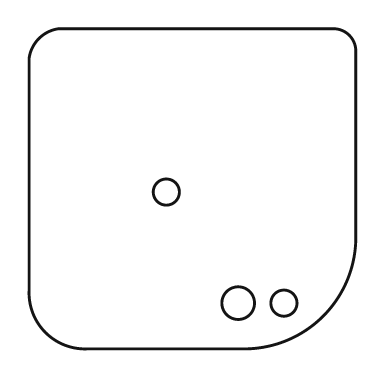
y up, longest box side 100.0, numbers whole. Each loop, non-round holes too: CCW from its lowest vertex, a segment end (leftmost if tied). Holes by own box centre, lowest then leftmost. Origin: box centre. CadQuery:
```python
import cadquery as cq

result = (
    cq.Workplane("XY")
    .moveTo(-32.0, -49.0)
    .lineTo(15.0, -49.0)
    .threePointArc((40.0, -39.0), (50.0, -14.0))
    .lineTo(50.0, 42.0)
    .threePointArc((48.0, 47.0), (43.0, 49.0))
    .lineTo(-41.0, 49.0)
    .threePointArc((-47.0, 46.0), (-50.0, 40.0))
    .lineTo(-50.0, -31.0)
    .threePointArc((-45.0, -44.0), (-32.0, -49.0))
    .close()
    .moveTo(14.0, -35.0)
    .circle(5.0)
    .moveTo(28.0, -35.0)
    .circle(4.0)
    .moveTo(-8.0, -1.0)
    .circle(4.0)
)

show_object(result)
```